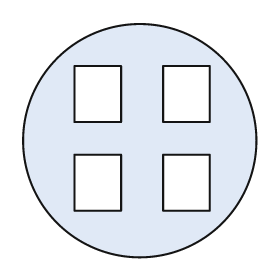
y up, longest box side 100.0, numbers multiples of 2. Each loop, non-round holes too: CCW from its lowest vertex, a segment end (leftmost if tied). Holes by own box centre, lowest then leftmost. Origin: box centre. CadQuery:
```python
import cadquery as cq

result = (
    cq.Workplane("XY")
    .moveTo(0.0, 0.0)
    .circle(50.0)
    .moveTo(-28.0, -30.0)
    .lineTo(-8.0, -30.0)
    .lineTo(-8.0, -6.0)
    .lineTo(-28.0, -6.0)
    .close()
    .moveTo(10.0, -30.0)
    .lineTo(30.0, -30.0)
    .lineTo(30.0, -6.0)
    .lineTo(10.0, -6.0)
    .close()
    .moveTo(-28.0, 8.0)
    .lineTo(-8.0, 8.0)
    .lineTo(-8.0, 32.0)
    .lineTo(-28.0, 32.0)
    .close()
    .moveTo(10.0, 8.0)
    .lineTo(30.0, 8.0)
    .lineTo(30.0, 32.0)
    .lineTo(10.0, 32.0)
    .close()
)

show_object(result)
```